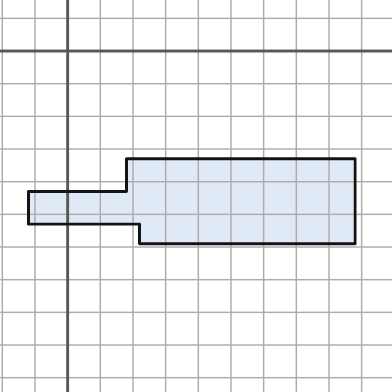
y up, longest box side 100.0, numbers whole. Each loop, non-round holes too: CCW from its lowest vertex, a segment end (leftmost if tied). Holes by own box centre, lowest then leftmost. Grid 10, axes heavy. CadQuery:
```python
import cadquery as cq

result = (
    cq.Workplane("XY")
    .moveTo(22.0, -59.0)
    .lineTo(88.0, -59.0)
    .lineTo(88.0, -33.0)
    .lineTo(18.0, -33.0)
    .lineTo(18.0, -43.0)
    .lineTo(-12.0, -43.0)
    .lineTo(-12.0, -53.0)
    .lineTo(22.0, -53.0)
    .close()
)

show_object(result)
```